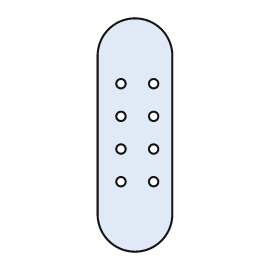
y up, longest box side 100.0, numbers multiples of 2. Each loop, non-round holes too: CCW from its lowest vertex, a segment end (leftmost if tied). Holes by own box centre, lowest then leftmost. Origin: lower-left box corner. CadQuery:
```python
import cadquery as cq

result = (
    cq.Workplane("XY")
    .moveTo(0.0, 16.0)
    .threePointArc((16.0, 0.0), (32.0, 16.0))
    .lineTo(32.0, 84.0)
    .threePointArc((16.0, 100.0), (0.0, 84.0))
    .close()
    .moveTo(10.0, 30.0)
    .circle(2.0)
    .moveTo(24.0, 30.0)
    .circle(2.0)
    .moveTo(10.0, 44.0)
    .circle(2.0)
    .moveTo(24.0, 44.0)
    .circle(2.0)
    .moveTo(10.0, 58.0)
    .circle(2.0)
    .moveTo(24.0, 58.0)
    .circle(2.0)
    .moveTo(10.0, 72.0)
    .circle(2.0)
    .moveTo(24.0, 72.0)
    .circle(2.0)
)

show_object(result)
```